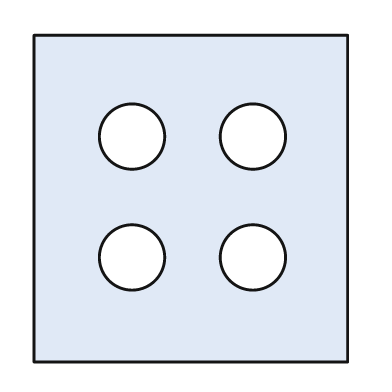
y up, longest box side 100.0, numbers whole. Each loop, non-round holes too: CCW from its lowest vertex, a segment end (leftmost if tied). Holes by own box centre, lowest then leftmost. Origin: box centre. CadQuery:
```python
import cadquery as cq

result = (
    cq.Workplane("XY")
    .moveTo(-48.0, -50.0)
    .lineTo(48.0, -50.0)
    .lineTo(48.0, 50.0)
    .lineTo(-48.0, 50.0)
    .close()
    .moveTo(-18.0, -18.0)
    .circle(10.0)
    .moveTo(19.0, -18.0)
    .circle(10.0)
    .moveTo(-18.0, 19.0)
    .circle(10.0)
    .moveTo(19.0, 19.0)
    .circle(10.0)
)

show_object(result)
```